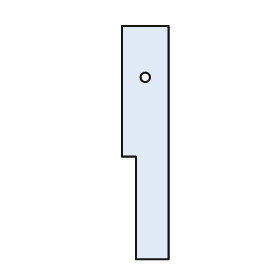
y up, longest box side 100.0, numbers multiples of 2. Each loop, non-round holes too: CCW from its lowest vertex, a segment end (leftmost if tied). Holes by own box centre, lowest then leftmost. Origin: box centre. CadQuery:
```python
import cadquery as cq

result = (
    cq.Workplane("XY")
    .moveTo(-4.0, -50.0)
    .lineTo(10.0, -50.0)
    .lineTo(10.0, 50.0)
    .lineTo(-10.0, 50.0)
    .lineTo(-10.0, -6.0)
    .lineTo(-4.0, -6.0)
    .close()
    .moveTo(0.0, 28.0)
    .circle(2.0)
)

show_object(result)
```